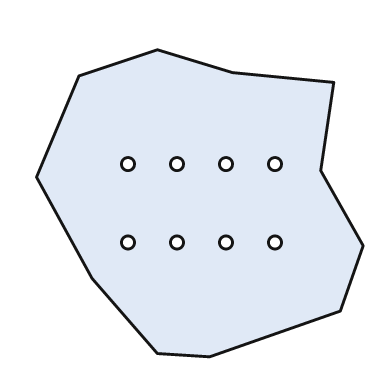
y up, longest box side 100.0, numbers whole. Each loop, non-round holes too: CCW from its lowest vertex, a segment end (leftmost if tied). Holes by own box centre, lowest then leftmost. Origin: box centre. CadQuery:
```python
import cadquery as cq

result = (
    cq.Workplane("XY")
    .moveTo(3.0, -47.0)
    .lineTo(43.0, -33.0)
    .lineTo(50.0, -13.0)
    .lineTo(37.0, 10.0)
    .lineTo(41.0, 37.0)
    .lineTo(10.0, 40.0)
    .lineTo(-13.0, 47.0)
    .lineTo(-37.0, 39.0)
    .lineTo(-50.0, 8.0)
    .lineTo(-33.0, -23.0)
    .lineTo(-13.0, -46.0)
    .close()
    .moveTo(-22.0, -12.0)
    .circle(2.0)
    .moveTo(-7.0, -12.0)
    .circle(2.0)
    .moveTo(8.0, -12.0)
    .circle(2.0)
    .moveTo(23.0, -12.0)
    .circle(2.0)
    .moveTo(-22.0, 12.0)
    .circle(2.0)
    .moveTo(-7.0, 12.0)
    .circle(2.0)
    .moveTo(8.0, 12.0)
    .circle(2.0)
    .moveTo(23.0, 12.0)
    .circle(2.0)
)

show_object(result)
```